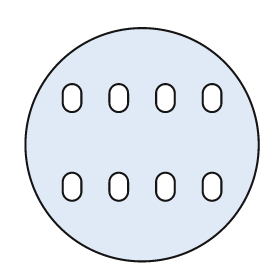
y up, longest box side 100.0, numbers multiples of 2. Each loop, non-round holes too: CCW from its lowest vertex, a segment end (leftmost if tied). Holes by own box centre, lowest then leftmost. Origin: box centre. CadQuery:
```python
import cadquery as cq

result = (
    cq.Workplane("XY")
    .moveTo(0.0, 0.0)
    .circle(50.0)
    .moveTo(-34.0, -20.0)
    .threePointArc((-30.0, -24.0), (-26.0, -20.0))
    .lineTo(-26.0, -16.0)
    .threePointArc((-30.0, -12.0), (-34.0, -16.0))
    .close()
    .moveTo(-14.0, -20.0)
    .threePointArc((-10.0, -24.0), (-6.0, -20.0))
    .lineTo(-6.0, -16.0)
    .threePointArc((-10.0, -12.0), (-14.0, -16.0))
    .close()
    .moveTo(6.0, -20.0)
    .threePointArc((10.0, -24.0), (14.0, -20.0))
    .lineTo(14.0, -16.0)
    .threePointArc((10.0, -12.0), (6.0, -16.0))
    .close()
    .moveTo(26.0, -20.0)
    .threePointArc((30.0, -24.0), (34.0, -20.0))
    .lineTo(34.0, -16.0)
    .threePointArc((30.0, -12.0), (26.0, -16.0))
    .close()
    .moveTo(-34.0, 18.0)
    .threePointArc((-30.0, 14.0), (-26.0, 18.0))
    .lineTo(-26.0, 22.0)
    .threePointArc((-30.0, 26.0), (-34.0, 22.0))
    .close()
    .moveTo(-14.0, 18.0)
    .threePointArc((-10.0, 14.0), (-6.0, 18.0))
    .lineTo(-6.0, 22.0)
    .threePointArc((-10.0, 26.0), (-14.0, 22.0))
    .close()
    .moveTo(6.0, 18.0)
    .threePointArc((10.0, 14.0), (14.0, 18.0))
    .lineTo(14.0, 22.0)
    .threePointArc((10.0, 26.0), (6.0, 22.0))
    .close()
    .moveTo(26.0, 18.0)
    .threePointArc((30.0, 14.0), (34.0, 18.0))
    .lineTo(34.0, 22.0)
    .threePointArc((30.0, 26.0), (26.0, 22.0))
    .close()
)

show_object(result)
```